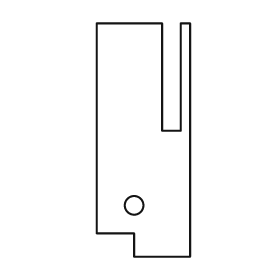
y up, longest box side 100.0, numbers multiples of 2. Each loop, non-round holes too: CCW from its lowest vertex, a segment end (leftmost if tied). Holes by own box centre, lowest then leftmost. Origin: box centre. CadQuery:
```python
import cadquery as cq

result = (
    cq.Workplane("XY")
    .moveTo(-4.0, -50.0)
    .lineTo(20.0, -50.0)
    .lineTo(20.0, 50.0)
    .lineTo(16.0, 50.0)
    .lineTo(16.0, 4.0)
    .lineTo(8.0, 4.0)
    .lineTo(8.0, 50.0)
    .lineTo(-20.0, 50.0)
    .lineTo(-20.0, -40.0)
    .lineTo(-4.0, -40.0)
    .close()
    .moveTo(-4.0, -28.0)
    .circle(4.0)
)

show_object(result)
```